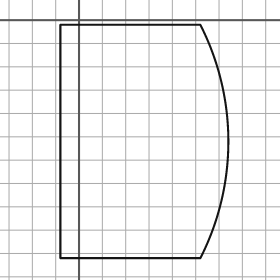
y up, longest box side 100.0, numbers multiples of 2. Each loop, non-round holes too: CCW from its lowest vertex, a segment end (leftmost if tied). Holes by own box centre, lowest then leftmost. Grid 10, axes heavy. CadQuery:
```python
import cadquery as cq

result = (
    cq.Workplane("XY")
    .moveTo(-8.0, -102.0)
    .lineTo(52.0, -102.0)
    .threePointArc((64.0, -52.0), (52.0, -2.0))
    .lineTo(-8.0, -2.0)
    .close()
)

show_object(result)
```